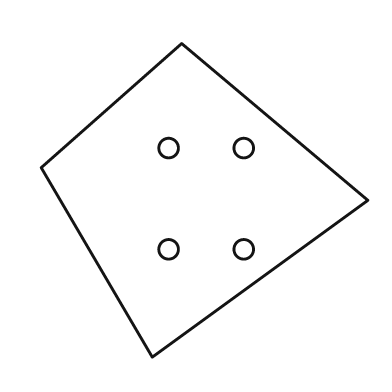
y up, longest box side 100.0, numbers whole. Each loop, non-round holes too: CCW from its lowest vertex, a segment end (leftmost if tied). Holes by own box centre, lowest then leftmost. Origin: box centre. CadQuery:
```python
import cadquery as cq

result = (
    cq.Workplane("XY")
    .moveTo(-16.0, -48.0)
    .lineTo(50.0, 0.0)
    .lineTo(-7.0, 48.0)
    .lineTo(-50.0, 10.0)
    .close()
    .moveTo(-11.0, -15.0)
    .circle(3.0)
    .moveTo(12.0, -15.0)
    .circle(3.0)
    .moveTo(-11.0, 16.0)
    .circle(3.0)
    .moveTo(12.0, 16.0)
    .circle(3.0)
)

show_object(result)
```